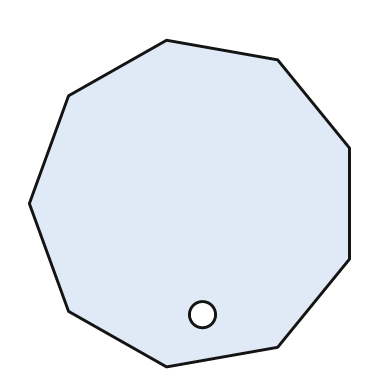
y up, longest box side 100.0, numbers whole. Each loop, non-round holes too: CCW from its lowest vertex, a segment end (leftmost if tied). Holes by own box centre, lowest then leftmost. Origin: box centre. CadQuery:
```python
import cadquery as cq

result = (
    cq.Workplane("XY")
    .moveTo(-7.0, -50.0)
    .lineTo(27.0, -44.0)
    .lineTo(49.0, -17.0)
    .lineTo(49.0, 17.0)
    .lineTo(27.0, 44.0)
    .lineTo(-7.0, 50.0)
    .lineTo(-37.0, 33.0)
    .lineTo(-49.0, 0.0)
    .lineTo(-37.0, -33.0)
    .close()
    .moveTo(4.0, -34.0)
    .circle(4.0)
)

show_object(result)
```